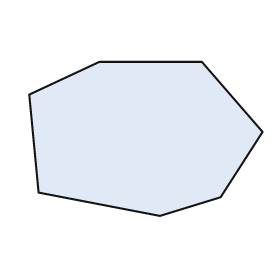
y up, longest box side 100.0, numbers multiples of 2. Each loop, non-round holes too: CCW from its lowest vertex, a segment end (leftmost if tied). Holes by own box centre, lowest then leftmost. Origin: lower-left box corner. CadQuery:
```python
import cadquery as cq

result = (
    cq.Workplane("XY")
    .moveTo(56.0, 0.0)
    .lineTo(82.0, 8.0)
    .lineTo(100.0, 36.0)
    .lineTo(74.0, 66.0)
    .lineTo(30.0, 66.0)
    .lineTo(0.0, 52.0)
    .lineTo(4.0, 10.0)
    .close()
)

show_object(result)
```